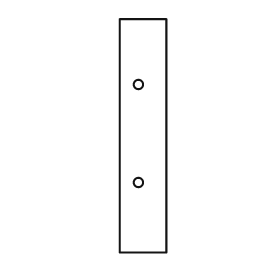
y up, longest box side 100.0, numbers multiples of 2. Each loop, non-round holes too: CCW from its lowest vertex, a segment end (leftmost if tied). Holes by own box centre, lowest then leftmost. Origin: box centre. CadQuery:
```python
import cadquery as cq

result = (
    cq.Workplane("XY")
    .moveTo(-10.0, -50.0)
    .lineTo(10.0, -50.0)
    .lineTo(10.0, 50.0)
    .lineTo(-10.0, 50.0)
    .close()
    .moveTo(-2.0, -20.0)
    .circle(2.0)
    .moveTo(-2.0, 22.0)
    .circle(2.0)
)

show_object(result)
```